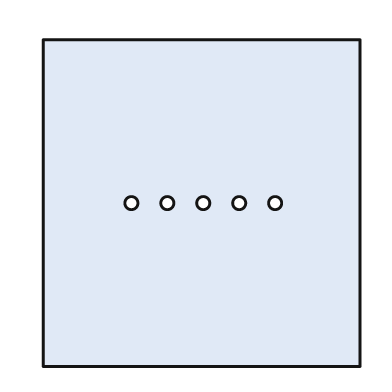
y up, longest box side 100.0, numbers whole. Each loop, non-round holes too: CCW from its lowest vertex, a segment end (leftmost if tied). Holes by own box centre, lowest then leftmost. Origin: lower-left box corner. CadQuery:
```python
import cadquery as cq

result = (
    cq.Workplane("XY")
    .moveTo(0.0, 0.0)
    .lineTo(97.0, 0.0)
    .lineTo(97.0, 100.0)
    .lineTo(0.0, 100.0)
    .close()
    .moveTo(27.0, 50.0)
    .circle(2.0)
    .moveTo(38.0, 50.0)
    .circle(2.0)
    .moveTo(49.0, 50.0)
    .circle(2.0)
    .moveTo(60.0, 50.0)
    .circle(2.0)
    .moveTo(71.0, 50.0)
    .circle(2.0)
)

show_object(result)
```